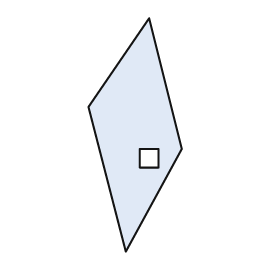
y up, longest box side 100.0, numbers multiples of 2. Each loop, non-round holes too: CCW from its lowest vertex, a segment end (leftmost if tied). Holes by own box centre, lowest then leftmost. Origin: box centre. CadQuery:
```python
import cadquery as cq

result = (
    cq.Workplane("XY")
    .moveTo(-4.0, -50.0)
    .lineTo(20.0, -6.0)
    .lineTo(6.0, 50.0)
    .lineTo(-20.0, 12.0)
    .close()
    .moveTo(2.0, -14.0)
    .lineTo(10.0, -14.0)
    .lineTo(10.0, -6.0)
    .lineTo(2.0, -6.0)
    .close()
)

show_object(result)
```